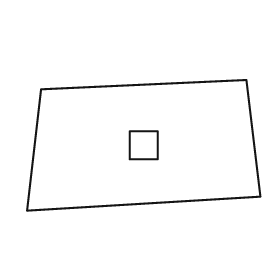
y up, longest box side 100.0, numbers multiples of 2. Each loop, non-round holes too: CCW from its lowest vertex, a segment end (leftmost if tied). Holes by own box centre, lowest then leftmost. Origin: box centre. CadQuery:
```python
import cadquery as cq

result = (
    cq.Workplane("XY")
    .moveTo(-50.0, -28.0)
    .lineTo(50.0, -22.0)
    .lineTo(44.0, 28.0)
    .lineTo(-44.0, 24.0)
    .close()
    .moveTo(-6.0, -6.0)
    .lineTo(6.0, -6.0)
    .lineTo(6.0, 6.0)
    .lineTo(-6.0, 6.0)
    .close()
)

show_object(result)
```